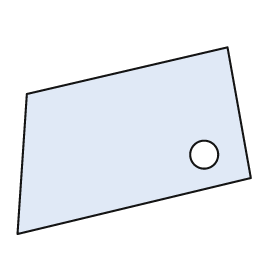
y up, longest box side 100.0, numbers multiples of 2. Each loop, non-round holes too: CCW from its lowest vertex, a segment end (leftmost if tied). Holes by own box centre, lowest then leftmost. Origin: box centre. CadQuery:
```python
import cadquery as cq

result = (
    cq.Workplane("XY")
    .moveTo(-50.0, -40.0)
    .lineTo(50.0, -16.0)
    .lineTo(40.0, 40.0)
    .lineTo(-46.0, 20.0)
    .close()
    .moveTo(30.0, -6.0)
    .circle(6.0)
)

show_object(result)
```